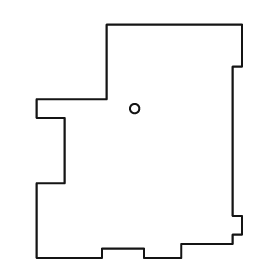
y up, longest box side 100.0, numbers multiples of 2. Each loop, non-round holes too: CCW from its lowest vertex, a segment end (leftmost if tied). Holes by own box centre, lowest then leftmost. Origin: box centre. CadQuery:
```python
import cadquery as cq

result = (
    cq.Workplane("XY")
    .moveTo(-44.0, -50.0)
    .lineTo(-16.0, -50.0)
    .lineTo(-16.0, -46.0)
    .lineTo(2.0, -46.0)
    .lineTo(2.0, -50.0)
    .lineTo(18.0, -50.0)
    .lineTo(18.0, -44.0)
    .lineTo(40.0, -44.0)
    .lineTo(40.0, -40.0)
    .lineTo(44.0, -40.0)
    .lineTo(44.0, -32.0)
    .lineTo(40.0, -32.0)
    .lineTo(40.0, 32.0)
    .lineTo(44.0, 32.0)
    .lineTo(44.0, 50.0)
    .lineTo(-14.0, 50.0)
    .lineTo(-14.0, 18.0)
    .lineTo(-44.0, 18.0)
    .lineTo(-44.0, 10.0)
    .lineTo(-32.0, 10.0)
    .lineTo(-32.0, -18.0)
    .lineTo(-44.0, -18.0)
    .close()
    .moveTo(-2.0, 14.0)
    .circle(2.0)
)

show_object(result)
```